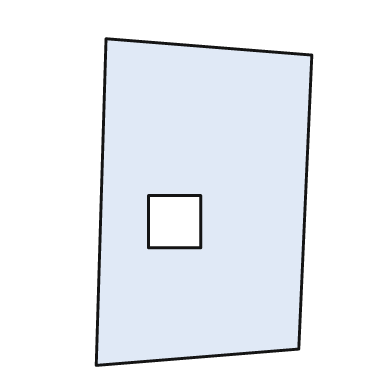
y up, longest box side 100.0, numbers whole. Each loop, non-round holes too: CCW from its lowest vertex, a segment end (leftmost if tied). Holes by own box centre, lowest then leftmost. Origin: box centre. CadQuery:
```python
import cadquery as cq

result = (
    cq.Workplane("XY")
    .moveTo(-33.0, -50.0)
    .lineTo(29.0, -45.0)
    .lineTo(33.0, 45.0)
    .lineTo(-30.0, 50.0)
    .close()
    .moveTo(-17.0, -14.0)
    .lineTo(-1.0, -14.0)
    .lineTo(-1.0, 2.0)
    .lineTo(-17.0, 2.0)
    .close()
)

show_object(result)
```